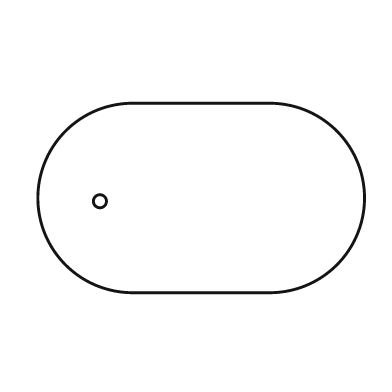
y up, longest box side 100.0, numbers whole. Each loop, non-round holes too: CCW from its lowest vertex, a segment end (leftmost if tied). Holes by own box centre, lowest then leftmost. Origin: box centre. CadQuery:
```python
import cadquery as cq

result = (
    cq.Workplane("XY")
    .moveTo(-21.0, -29.0)
    .lineTo(21.0, -29.0)
    .threePointArc((50.0, 0.0), (21.0, 29.0))
    .lineTo(-21.0, 29.0)
    .threePointArc((-50.0, 0.0), (-21.0, -29.0))
    .close()
    .moveTo(-31.0, -1.0)
    .circle(2.0)
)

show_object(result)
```